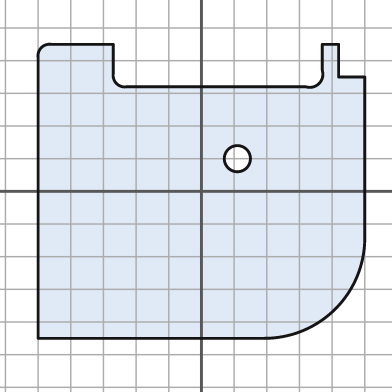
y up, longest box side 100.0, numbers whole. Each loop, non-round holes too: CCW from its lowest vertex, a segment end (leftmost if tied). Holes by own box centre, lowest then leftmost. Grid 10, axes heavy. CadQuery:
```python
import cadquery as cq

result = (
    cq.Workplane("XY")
    .moveTo(-50.0, -45.0)
    .lineTo(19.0, -45.0)
    .threePointArc((41.0, -36.0), (50.0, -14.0))
    .lineTo(50.0, 35.0)
    .lineTo(42.0, 35.0)
    .lineTo(42.0, 45.0)
    .lineTo(37.0, 45.0)
    .lineTo(37.0, 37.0)
    .threePointArc((36.0, 33.0), (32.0, 32.0))
    .lineTo(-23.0, 32.0)
    .threePointArc((-26.0, 33.0), (-27.0, 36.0))
    .lineTo(-27.0, 45.0)
    .lineTo(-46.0, 45.0)
    .threePointArc((-49.0, 44.0), (-50.0, 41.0))
    .close()
    .moveTo(11.0, 10.0)
    .circle(4.0)
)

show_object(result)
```